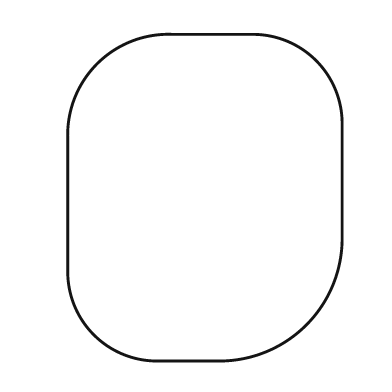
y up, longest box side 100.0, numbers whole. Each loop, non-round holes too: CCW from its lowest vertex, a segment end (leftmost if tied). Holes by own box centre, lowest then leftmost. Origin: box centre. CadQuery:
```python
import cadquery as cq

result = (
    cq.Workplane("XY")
    .moveTo(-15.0, -50.0)
    .lineTo(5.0, -50.0)
    .threePointArc((31.0, -39.0), (42.0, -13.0))
    .lineTo(42.0, 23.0)
    .threePointArc((34.0, 42.0), (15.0, 50.0))
    .lineTo(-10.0, 50.0)
    .threePointArc((-33.0, 41.0), (-42.0, 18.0))
    .lineTo(-42.0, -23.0)
    .threePointArc((-34.0, -42.0), (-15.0, -50.0))
    .close()
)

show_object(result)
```